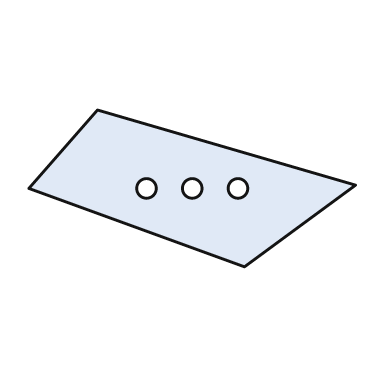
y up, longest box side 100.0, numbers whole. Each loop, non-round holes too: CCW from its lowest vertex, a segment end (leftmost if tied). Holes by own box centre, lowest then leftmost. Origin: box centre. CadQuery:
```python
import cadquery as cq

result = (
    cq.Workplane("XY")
    .moveTo(16.0, -24.0)
    .lineTo(50.0, 1.0)
    .lineTo(-29.0, 24.0)
    .lineTo(-50.0, 0.0)
    .close()
    .moveTo(-14.0, 0.0)
    .circle(3.0)
    .moveTo(0.0, 0.0)
    .circle(3.0)
    .moveTo(14.0, 0.0)
    .circle(3.0)
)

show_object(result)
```